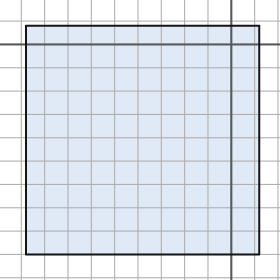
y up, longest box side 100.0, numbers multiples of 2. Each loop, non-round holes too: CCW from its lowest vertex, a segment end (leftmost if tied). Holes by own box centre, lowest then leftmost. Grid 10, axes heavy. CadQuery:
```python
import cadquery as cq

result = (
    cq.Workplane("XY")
    .moveTo(-88.0, -90.0)
    .lineTo(12.0, -90.0)
    .lineTo(12.0, 8.0)
    .lineTo(-88.0, 8.0)
    .close()
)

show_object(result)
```